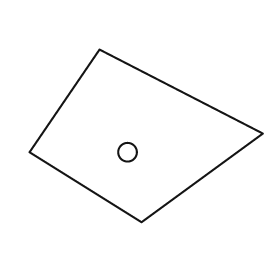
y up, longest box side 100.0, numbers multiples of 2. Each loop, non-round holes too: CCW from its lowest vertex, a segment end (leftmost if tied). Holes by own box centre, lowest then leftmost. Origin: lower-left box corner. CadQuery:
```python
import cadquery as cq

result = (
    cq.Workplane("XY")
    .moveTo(48.0, 0.0)
    .lineTo(100.0, 38.0)
    .lineTo(30.0, 74.0)
    .lineTo(0.0, 30.0)
    .close()
    .moveTo(42.0, 30.0)
    .circle(4.0)
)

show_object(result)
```